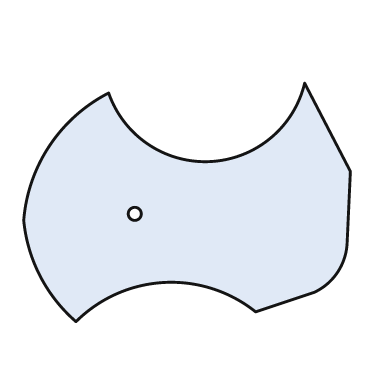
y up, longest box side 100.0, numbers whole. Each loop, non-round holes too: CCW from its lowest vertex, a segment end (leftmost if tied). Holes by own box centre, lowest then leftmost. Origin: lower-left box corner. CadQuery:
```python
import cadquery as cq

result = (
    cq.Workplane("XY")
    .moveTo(16.0, 0.0)
    .threePointArc((43.0, 12.0), (71.0, 3.0))
    .lineTo(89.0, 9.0)
    .threePointArc((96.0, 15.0), (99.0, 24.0))
    .lineTo(100.0, 46.0)
    .lineTo(86.0, 73.0)
    .threePointArc((57.0, 49.0), (26.0, 70.0))
    .threePointArc((8.0, 54.0), (0.0, 31.0))
    .threePointArc((5.0, 14.0), (16.0, 0.0))
    .close()
    .moveTo(34.0, 33.0)
    .circle(2.0)
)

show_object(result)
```